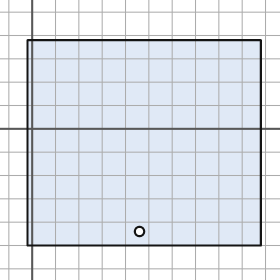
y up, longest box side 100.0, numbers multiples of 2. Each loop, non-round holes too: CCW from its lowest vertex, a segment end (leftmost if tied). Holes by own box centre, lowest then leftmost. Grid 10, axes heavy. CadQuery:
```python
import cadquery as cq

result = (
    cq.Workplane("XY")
    .moveTo(-2.0, -50.0)
    .lineTo(98.0, -50.0)
    .lineTo(98.0, 38.0)
    .lineTo(-2.0, 38.0)
    .close()
    .moveTo(46.0, -44.0)
    .circle(2.0)
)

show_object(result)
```